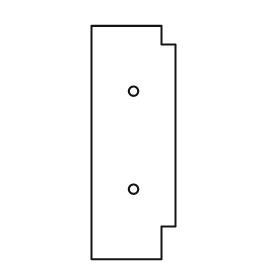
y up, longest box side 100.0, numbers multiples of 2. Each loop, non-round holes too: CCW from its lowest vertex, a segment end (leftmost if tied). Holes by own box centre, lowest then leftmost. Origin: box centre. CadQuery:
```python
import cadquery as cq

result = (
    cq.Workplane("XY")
    .moveTo(-18.0, -50.0)
    .lineTo(12.0, -50.0)
    .lineTo(12.0, -36.0)
    .lineTo(18.0, -36.0)
    .lineTo(18.0, 42.0)
    .lineTo(12.0, 42.0)
    .lineTo(12.0, 50.0)
    .lineTo(-18.0, 50.0)
    .close()
    .moveTo(0.0, -20.0)
    .circle(2.0)
    .moveTo(0.0, 22.0)
    .circle(2.0)
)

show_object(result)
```